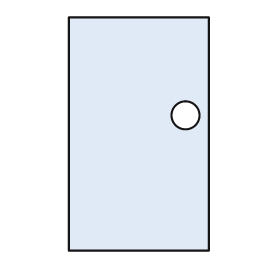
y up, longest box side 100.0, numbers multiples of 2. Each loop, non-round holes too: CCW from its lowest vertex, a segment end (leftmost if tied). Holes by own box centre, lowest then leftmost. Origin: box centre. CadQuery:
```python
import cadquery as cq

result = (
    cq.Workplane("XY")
    .moveTo(-30.0, -50.0)
    .lineTo(30.0, -50.0)
    .lineTo(30.0, 50.0)
    .lineTo(-30.0, 50.0)
    .close()
    .moveTo(20.0, 8.0)
    .circle(6.0)
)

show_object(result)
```